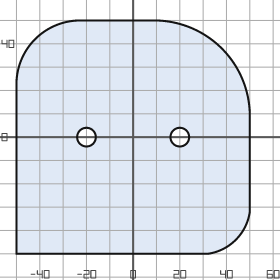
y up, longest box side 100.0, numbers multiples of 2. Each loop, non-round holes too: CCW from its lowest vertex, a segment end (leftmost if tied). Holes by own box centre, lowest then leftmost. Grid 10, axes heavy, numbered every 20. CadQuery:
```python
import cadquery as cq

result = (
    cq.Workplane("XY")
    .moveTo(-50.0, -50.0)
    .lineTo(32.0, -50.0)
    .threePointArc((44.0, -44.0), (50.0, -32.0))
    .lineTo(50.0, 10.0)
    .threePointArc((38.0, 38.0), (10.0, 50.0))
    .lineTo(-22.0, 50.0)
    .threePointArc((-42.0, 42.0), (-50.0, 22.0))
    .close()
    .moveTo(-20.0, 0.0)
    .circle(4.0)
    .moveTo(20.0, 0.0)
    .circle(4.0)
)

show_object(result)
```